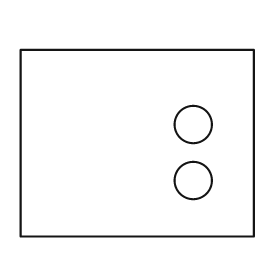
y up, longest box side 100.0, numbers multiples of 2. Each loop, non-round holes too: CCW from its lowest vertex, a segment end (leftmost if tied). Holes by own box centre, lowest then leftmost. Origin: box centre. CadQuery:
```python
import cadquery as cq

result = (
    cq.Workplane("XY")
    .moveTo(-50.0, -40.0)
    .lineTo(50.0, -40.0)
    .lineTo(50.0, 40.0)
    .lineTo(-50.0, 40.0)
    .close()
    .moveTo(24.0, -16.0)
    .circle(8.0)
    .moveTo(24.0, 8.0)
    .circle(8.0)
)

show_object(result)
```